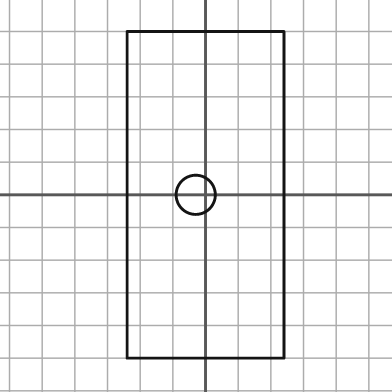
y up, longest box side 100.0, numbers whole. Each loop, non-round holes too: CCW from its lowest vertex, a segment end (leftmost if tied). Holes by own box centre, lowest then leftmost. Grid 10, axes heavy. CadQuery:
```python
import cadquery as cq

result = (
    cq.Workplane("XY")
    .moveTo(-24.0, -50.0)
    .lineTo(24.0, -50.0)
    .lineTo(24.0, 50.0)
    .lineTo(-24.0, 50.0)
    .close()
    .moveTo(-3.0, 0.0)
    .circle(6.0)
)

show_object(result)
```